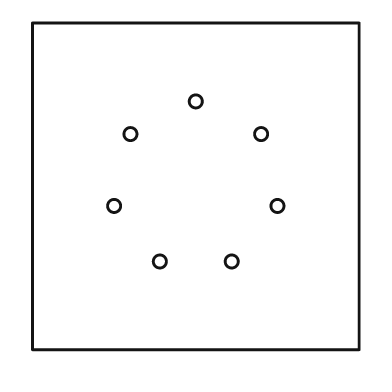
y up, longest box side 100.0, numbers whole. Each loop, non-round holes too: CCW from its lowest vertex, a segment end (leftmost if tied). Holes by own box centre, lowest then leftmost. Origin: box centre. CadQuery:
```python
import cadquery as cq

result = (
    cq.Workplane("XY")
    .moveTo(-50.0, -50.0)
    .lineTo(50.0, -50.0)
    .lineTo(50.0, 50.0)
    .lineTo(-50.0, 50.0)
    .close()
    .moveTo(-11.0, -23.0)
    .circle(2.0)
    .moveTo(11.0, -23.0)
    .circle(2.0)
    .moveTo(-25.0, -6.0)
    .circle(2.0)
    .moveTo(25.0, -6.0)
    .circle(2.0)
    .moveTo(-20.0, 16.0)
    .circle(2.0)
    .moveTo(20.0, 16.0)
    .circle(2.0)
    .moveTo(0.0, 26.0)
    .circle(2.0)
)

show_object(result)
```